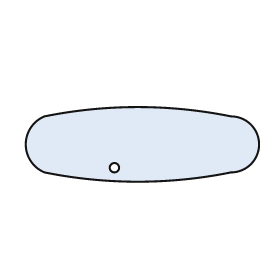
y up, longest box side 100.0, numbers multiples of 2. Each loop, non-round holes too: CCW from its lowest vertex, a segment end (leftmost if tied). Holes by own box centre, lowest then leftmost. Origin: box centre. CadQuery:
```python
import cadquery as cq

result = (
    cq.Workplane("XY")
    .moveTo(-42.0, -12.0)
    .threePointArc((-2.0, -16.0), (38.0, -12.0))
    .threePointArc((50.0, 0.0), (38.0, 12.0))
    .threePointArc((-2.0, 16.0), (-42.0, 12.0))
    .threePointArc((-50.0, 0.0), (-42.0, -12.0))
    .close()
    .moveTo(-12.0, -10.0)
    .circle(2.0)
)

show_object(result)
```